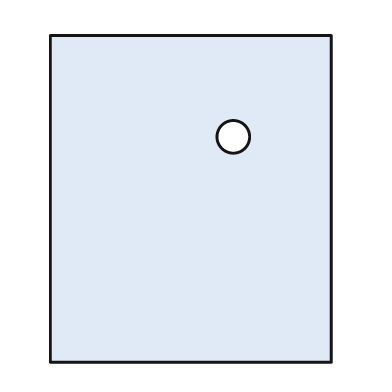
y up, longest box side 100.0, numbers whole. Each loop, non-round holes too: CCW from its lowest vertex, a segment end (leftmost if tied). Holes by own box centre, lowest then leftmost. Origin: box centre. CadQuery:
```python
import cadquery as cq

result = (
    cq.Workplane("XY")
    .moveTo(-43.0, -50.0)
    .lineTo(43.0, -50.0)
    .lineTo(43.0, 50.0)
    .lineTo(-43.0, 50.0)
    .close()
    .moveTo(13.0, 19.0)
    .circle(5.0)
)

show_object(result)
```